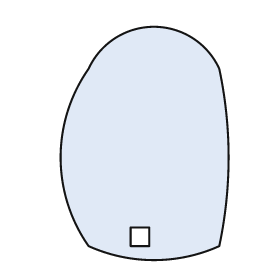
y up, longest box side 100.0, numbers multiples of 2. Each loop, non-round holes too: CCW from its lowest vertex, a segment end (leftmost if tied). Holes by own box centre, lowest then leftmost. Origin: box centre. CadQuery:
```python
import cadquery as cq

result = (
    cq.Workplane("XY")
    .moveTo(-24.0, -44.0)
    .threePointArc((4.0, -50.0), (32.0, -44.0))
    .threePointArc((36.0, -6.0), (32.0, 32.0))
    .threePointArc((4.0, 50.0), (-24.0, 32.0))
    .threePointArc((-36.0, -6.0), (-24.0, -44.0))
    .close()
    .moveTo(-6.0, -44.0)
    .lineTo(2.0, -44.0)
    .lineTo(2.0, -36.0)
    .lineTo(-6.0, -36.0)
    .close()
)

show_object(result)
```